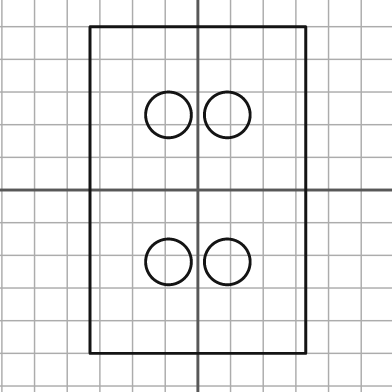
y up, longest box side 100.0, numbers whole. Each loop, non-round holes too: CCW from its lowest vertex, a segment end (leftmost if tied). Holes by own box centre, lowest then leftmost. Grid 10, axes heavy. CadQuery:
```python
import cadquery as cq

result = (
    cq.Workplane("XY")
    .moveTo(-33.0, -50.0)
    .lineTo(33.0, -50.0)
    .lineTo(33.0, 50.0)
    .lineTo(-33.0, 50.0)
    .close()
    .moveTo(-9.0, -22.0)
    .circle(7.0)
    .moveTo(9.0, -22.0)
    .circle(7.0)
    .moveTo(-9.0, 23.0)
    .circle(7.0)
    .moveTo(9.0, 23.0)
    .circle(7.0)
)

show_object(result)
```